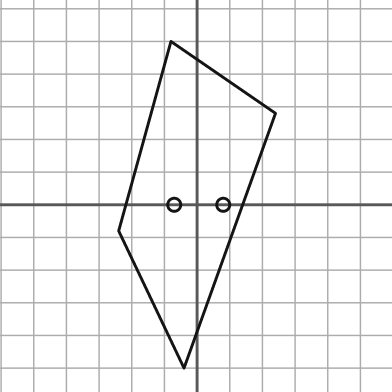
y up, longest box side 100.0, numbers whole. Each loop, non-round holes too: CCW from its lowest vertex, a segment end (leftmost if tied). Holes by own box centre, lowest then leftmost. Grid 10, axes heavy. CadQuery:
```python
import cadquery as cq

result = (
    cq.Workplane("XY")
    .moveTo(-4.0, -50.0)
    .lineTo(24.0, 28.0)
    .lineTo(-8.0, 50.0)
    .lineTo(-24.0, -8.0)
    .close()
    .moveTo(-7.0, 0.0)
    .circle(2.0)
    .moveTo(8.0, 0.0)
    .circle(2.0)
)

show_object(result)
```